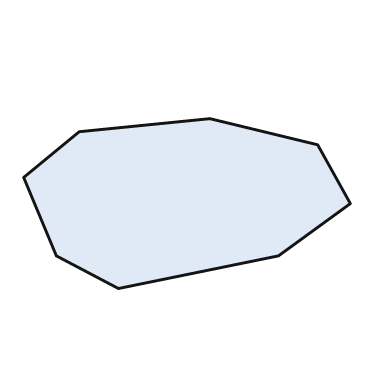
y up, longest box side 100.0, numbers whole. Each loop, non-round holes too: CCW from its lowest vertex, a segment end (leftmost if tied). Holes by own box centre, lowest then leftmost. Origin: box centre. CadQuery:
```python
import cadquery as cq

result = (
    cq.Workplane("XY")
    .moveTo(-21.0, -26.0)
    .lineTo(28.0, -16.0)
    .lineTo(50.0, 0.0)
    .lineTo(40.0, 18.0)
    .lineTo(7.0, 26.0)
    .lineTo(-33.0, 22.0)
    .lineTo(-50.0, 8.0)
    .lineTo(-40.0, -16.0)
    .close()
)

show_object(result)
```